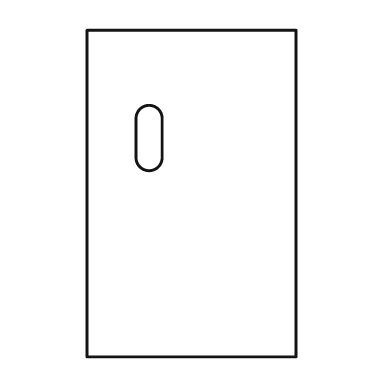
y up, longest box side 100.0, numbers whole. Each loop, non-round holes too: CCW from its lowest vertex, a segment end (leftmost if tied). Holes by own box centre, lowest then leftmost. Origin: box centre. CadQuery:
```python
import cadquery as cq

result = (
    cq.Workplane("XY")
    .moveTo(-32.0, -50.0)
    .lineTo(32.0, -50.0)
    .lineTo(32.0, 50.0)
    .lineTo(-32.0, 50.0)
    .close()
    .moveTo(-17.0, 11.0)
    .threePointArc((-13.0, 7.0), (-9.0, 11.0))
    .lineTo(-9.0, 23.0)
    .threePointArc((-13.0, 27.0), (-17.0, 23.0))
    .close()
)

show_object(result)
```